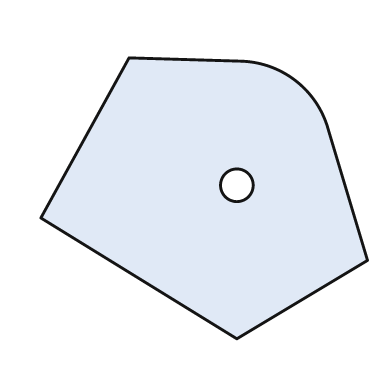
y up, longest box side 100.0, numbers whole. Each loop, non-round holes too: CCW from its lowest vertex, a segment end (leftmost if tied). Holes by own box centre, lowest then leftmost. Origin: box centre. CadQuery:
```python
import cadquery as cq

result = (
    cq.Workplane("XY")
    .moveTo(10.0, -43.0)
    .lineTo(50.0, -19.0)
    .lineTo(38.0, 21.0)
    .threePointArc((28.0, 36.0), (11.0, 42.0))
    .lineTo(-23.0, 43.0)
    .lineTo(-50.0, -6.0)
    .close()
    .moveTo(10.0, 4.0)
    .circle(5.0)
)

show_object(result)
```